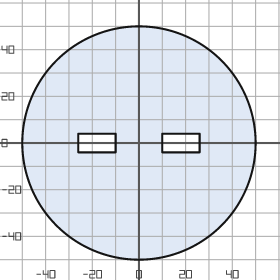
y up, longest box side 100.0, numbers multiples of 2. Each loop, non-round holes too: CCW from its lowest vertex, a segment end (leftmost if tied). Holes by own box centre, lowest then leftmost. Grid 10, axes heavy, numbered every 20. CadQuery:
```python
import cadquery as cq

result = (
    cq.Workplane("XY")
    .moveTo(0.0, 0.0)
    .circle(50.0)
    .moveTo(-26.0, -4.0)
    .lineTo(-10.0, -4.0)
    .lineTo(-10.0, 4.0)
    .lineTo(-26.0, 4.0)
    .close()
    .moveTo(10.0, -4.0)
    .lineTo(26.0, -4.0)
    .lineTo(26.0, 4.0)
    .lineTo(10.0, 4.0)
    .close()
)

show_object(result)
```